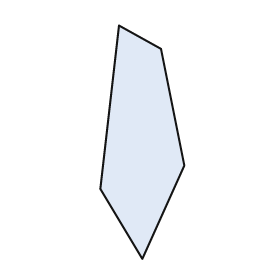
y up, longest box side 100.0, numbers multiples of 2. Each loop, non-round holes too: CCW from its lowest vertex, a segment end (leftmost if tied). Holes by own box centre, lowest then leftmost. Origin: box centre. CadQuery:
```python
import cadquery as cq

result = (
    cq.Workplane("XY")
    .moveTo(0.0, -50.0)
    .lineTo(18.0, -10.0)
    .lineTo(8.0, 40.0)
    .lineTo(-10.0, 50.0)
    .lineTo(-18.0, -20.0)
    .close()
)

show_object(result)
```